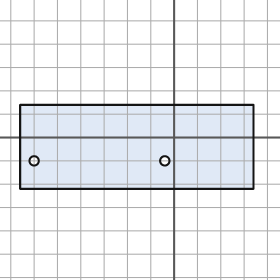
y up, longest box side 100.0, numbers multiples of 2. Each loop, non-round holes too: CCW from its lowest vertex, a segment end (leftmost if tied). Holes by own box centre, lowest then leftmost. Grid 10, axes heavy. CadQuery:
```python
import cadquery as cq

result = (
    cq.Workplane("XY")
    .moveTo(-66.0, -22.0)
    .lineTo(34.0, -22.0)
    .lineTo(34.0, 14.0)
    .lineTo(-66.0, 14.0)
    .close()
    .moveTo(-60.0, -10.0)
    .circle(2.0)
    .moveTo(-4.0, -10.0)
    .circle(2.0)
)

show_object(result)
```